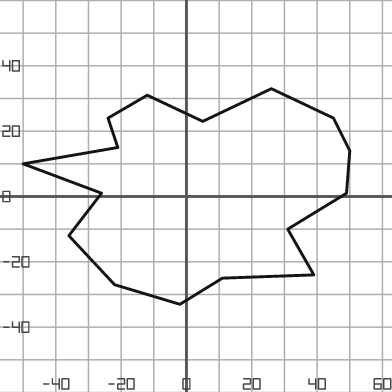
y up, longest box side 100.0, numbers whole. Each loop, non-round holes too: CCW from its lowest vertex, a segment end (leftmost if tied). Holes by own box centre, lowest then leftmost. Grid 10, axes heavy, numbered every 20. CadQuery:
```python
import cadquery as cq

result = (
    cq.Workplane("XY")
    .moveTo(-2.0, -33.0)
    .lineTo(11.0, -25.0)
    .lineTo(39.0, -24.0)
    .lineTo(31.0, -10.0)
    .lineTo(49.0, 1.0)
    .lineTo(50.0, 14.0)
    .lineTo(45.0, 24.0)
    .lineTo(26.0, 33.0)
    .lineTo(5.0, 23.0)
    .lineTo(-12.0, 31.0)
    .lineTo(-24.0, 24.0)
    .lineTo(-21.0, 15.0)
    .lineTo(-50.0, 10.0)
    .lineTo(-26.0, 1.0)
    .lineTo(-36.0, -12.0)
    .lineTo(-22.0, -27.0)
    .close()
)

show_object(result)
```